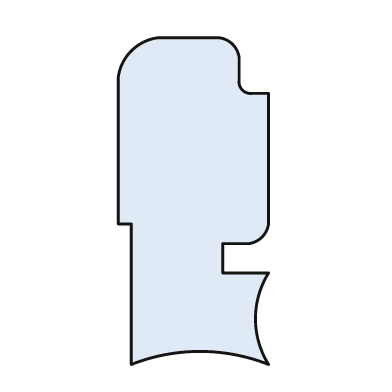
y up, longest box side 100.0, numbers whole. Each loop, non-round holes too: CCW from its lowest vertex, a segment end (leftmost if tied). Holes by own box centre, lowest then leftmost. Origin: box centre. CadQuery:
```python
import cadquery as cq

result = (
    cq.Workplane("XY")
    .moveTo(-19.0, -50.0)
    .threePointArc((2.0, -46.0), (23.0, -50.0))
    .threePointArc((19.0, -36.0), (23.0, -22.0))
    .lineTo(9.0, -22.0)
    .lineTo(9.0, -13.0)
    .lineTo(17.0, -13.0)
    .threePointArc((21.0, -11.0), (23.0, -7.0))
    .lineTo(23.0, 33.0)
    .lineTo(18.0, 33.0)
    .threePointArc((15.0, 34.0), (14.0, 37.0))
    .lineTo(14.0, 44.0)
    .threePointArc((12.0, 48.0), (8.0, 50.0))
    .lineTo(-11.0, 50.0)
    .threePointArc((-19.0, 46.0), (-23.0, 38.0))
    .lineTo(-23.0, -7.0)
    .lineTo(-19.0, -7.0)
    .close()
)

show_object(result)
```